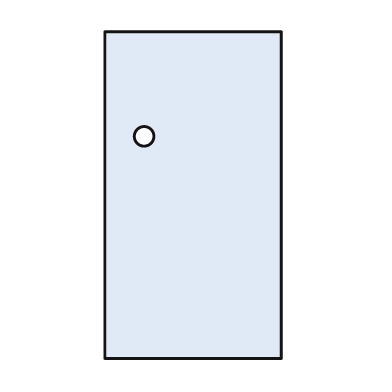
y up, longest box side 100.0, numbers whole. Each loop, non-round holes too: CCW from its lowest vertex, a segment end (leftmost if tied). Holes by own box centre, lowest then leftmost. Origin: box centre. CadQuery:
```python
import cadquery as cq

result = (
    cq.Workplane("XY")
    .moveTo(-27.0, -50.0)
    .lineTo(27.0, -50.0)
    .lineTo(27.0, 50.0)
    .lineTo(-27.0, 50.0)
    .close()
    .moveTo(-15.0, 18.0)
    .circle(3.0)
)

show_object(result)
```